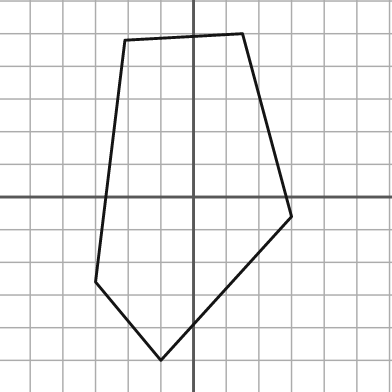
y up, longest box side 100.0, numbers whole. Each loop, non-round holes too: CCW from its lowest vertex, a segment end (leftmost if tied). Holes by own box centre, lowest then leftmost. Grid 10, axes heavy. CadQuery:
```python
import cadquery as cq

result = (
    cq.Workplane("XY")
    .moveTo(-10.0, -50.0)
    .lineTo(30.0, -6.0)
    .lineTo(15.0, 50.0)
    .lineTo(-21.0, 48.0)
    .lineTo(-30.0, -26.0)
    .close()
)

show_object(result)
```